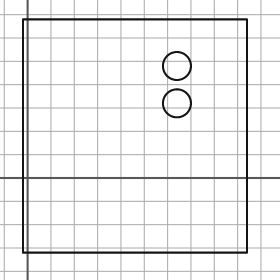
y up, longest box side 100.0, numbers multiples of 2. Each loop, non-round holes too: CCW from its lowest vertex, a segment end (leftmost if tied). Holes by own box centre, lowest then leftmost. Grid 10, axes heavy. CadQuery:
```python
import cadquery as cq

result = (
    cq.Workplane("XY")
    .moveTo(-2.0, -32.0)
    .lineTo(94.0, -32.0)
    .lineTo(94.0, 68.0)
    .lineTo(-2.0, 68.0)
    .close()
    .moveTo(64.0, 32.0)
    .circle(6.0)
    .moveTo(64.0, 48.0)
    .circle(6.0)
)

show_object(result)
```